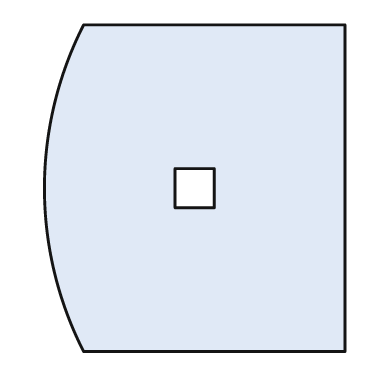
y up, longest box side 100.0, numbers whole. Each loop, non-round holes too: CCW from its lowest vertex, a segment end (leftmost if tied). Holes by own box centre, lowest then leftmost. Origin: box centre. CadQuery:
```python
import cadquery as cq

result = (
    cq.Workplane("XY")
    .moveTo(-34.0, -50.0)
    .lineTo(46.0, -50.0)
    .lineTo(46.0, 50.0)
    .lineTo(-34.0, 50.0)
    .threePointArc((-46.0, 0.0), (-34.0, -50.0))
    .close()
    .moveTo(-6.0, -6.0)
    .lineTo(6.0, -6.0)
    .lineTo(6.0, 6.0)
    .lineTo(-6.0, 6.0)
    .close()
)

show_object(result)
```